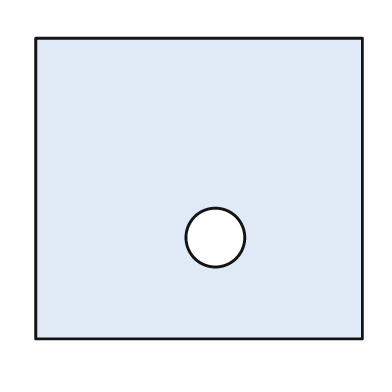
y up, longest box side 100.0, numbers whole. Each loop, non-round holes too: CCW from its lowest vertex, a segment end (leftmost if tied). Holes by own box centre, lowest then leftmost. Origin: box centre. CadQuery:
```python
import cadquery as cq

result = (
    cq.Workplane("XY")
    .moveTo(-50.0, -46.0)
    .lineTo(50.0, -46.0)
    .lineTo(50.0, 46.0)
    .lineTo(-50.0, 46.0)
    .close()
    .moveTo(5.0, -15.0)
    .circle(9.0)
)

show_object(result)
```